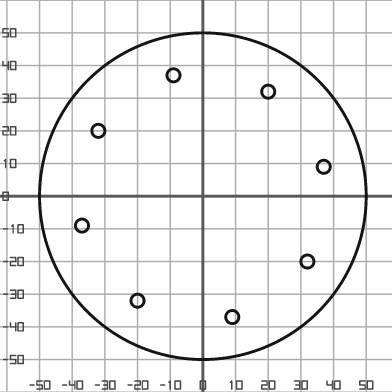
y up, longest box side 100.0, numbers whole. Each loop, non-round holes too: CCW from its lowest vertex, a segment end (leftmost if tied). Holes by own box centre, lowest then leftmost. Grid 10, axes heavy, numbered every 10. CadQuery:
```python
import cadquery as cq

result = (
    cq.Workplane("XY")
    .moveTo(0.0, 0.0)
    .circle(50.0)
    .moveTo(9.0, -37.0)
    .circle(2.0)
    .moveTo(-20.0, -32.0)
    .circle(2.0)
    .moveTo(32.0, -20.0)
    .circle(2.0)
    .moveTo(-37.0, -9.0)
    .circle(2.0)
    .moveTo(37.0, 9.0)
    .circle(2.0)
    .moveTo(-32.0, 20.0)
    .circle(2.0)
    .moveTo(20.0, 32.0)
    .circle(2.0)
    .moveTo(-9.0, 37.0)
    .circle(2.0)
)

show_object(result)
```